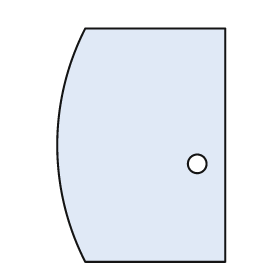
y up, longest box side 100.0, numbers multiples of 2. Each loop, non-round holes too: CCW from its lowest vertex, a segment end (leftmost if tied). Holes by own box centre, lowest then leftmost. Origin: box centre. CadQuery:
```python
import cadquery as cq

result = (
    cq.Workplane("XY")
    .moveTo(-24.0, -50.0)
    .lineTo(36.0, -50.0)
    .lineTo(36.0, 50.0)
    .lineTo(-24.0, 50.0)
    .threePointArc((-36.0, 0.0), (-24.0, -50.0))
    .close()
    .moveTo(24.0, -8.0)
    .circle(4.0)
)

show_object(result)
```